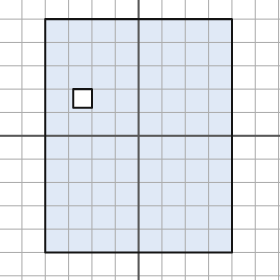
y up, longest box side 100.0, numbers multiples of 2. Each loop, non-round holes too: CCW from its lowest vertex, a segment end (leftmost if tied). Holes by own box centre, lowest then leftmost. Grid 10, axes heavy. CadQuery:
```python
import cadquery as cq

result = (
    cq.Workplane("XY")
    .moveTo(-40.0, -50.0)
    .lineTo(40.0, -50.0)
    .lineTo(40.0, 50.0)
    .lineTo(-40.0, 50.0)
    .close()
    .moveTo(-28.0, 12.0)
    .lineTo(-20.0, 12.0)
    .lineTo(-20.0, 20.0)
    .lineTo(-28.0, 20.0)
    .close()
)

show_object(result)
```